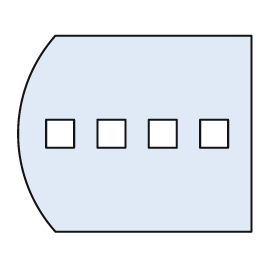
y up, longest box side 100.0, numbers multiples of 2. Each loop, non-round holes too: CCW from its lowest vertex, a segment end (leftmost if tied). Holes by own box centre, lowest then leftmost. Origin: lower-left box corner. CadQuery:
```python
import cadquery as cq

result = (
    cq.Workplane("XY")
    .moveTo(16.0, 0.0)
    .lineTo(100.0, 0.0)
    .lineTo(100.0, 84.0)
    .lineTo(16.0, 84.0)
    .threePointArc((0.0, 42.0), (16.0, 0.0))
    .close()
    .moveTo(12.0, 36.0)
    .lineTo(24.0, 36.0)
    .lineTo(24.0, 48.0)
    .lineTo(12.0, 48.0)
    .close()
    .moveTo(34.0, 36.0)
    .lineTo(46.0, 36.0)
    .lineTo(46.0, 48.0)
    .lineTo(34.0, 48.0)
    .close()
    .moveTo(56.0, 36.0)
    .lineTo(68.0, 36.0)
    .lineTo(68.0, 48.0)
    .lineTo(56.0, 48.0)
    .close()
    .moveTo(78.0, 36.0)
    .lineTo(90.0, 36.0)
    .lineTo(90.0, 48.0)
    .lineTo(78.0, 48.0)
    .close()
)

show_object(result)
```